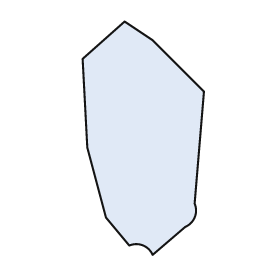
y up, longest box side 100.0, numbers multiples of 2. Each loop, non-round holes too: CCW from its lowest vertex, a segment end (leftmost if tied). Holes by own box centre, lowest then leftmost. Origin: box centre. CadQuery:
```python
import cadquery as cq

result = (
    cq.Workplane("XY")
    .moveTo(4.0, -50.0)
    .lineTo(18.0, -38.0)
    .threePointArc((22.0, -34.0), (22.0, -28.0))
    .lineTo(26.0, 20.0)
    .lineTo(4.0, 42.0)
    .lineTo(-8.0, 50.0)
    .lineTo(-26.0, 34.0)
    .lineTo(-24.0, -4.0)
    .lineTo(-16.0, -34.0)
    .lineTo(-6.0, -46.0)
    .threePointArc((0.0, -46.0), (4.0, -50.0))
    .close()
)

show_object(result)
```